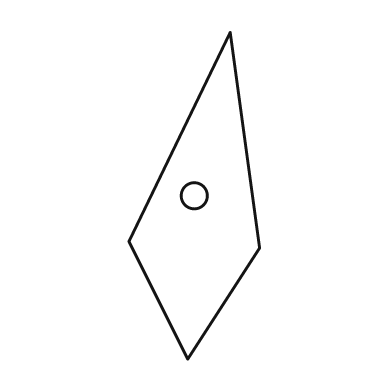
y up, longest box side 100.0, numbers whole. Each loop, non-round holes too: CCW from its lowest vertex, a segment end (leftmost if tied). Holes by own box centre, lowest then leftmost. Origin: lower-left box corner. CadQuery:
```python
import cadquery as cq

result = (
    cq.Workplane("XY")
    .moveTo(18.0, 0.0)
    .lineTo(40.0, 34.0)
    .lineTo(31.0, 100.0)
    .lineTo(0.0, 36.0)
    .close()
    .moveTo(20.0, 50.0)
    .circle(4.0)
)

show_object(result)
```